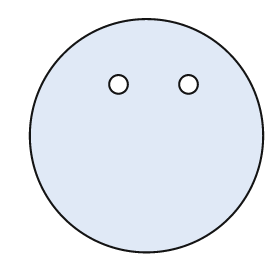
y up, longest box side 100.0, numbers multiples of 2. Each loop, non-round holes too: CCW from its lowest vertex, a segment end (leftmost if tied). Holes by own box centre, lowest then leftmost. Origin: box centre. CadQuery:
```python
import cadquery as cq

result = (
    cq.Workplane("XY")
    .moveTo(0.0, 0.0)
    .circle(50.0)
    .moveTo(-12.0, 22.0)
    .circle(4.0)
    .moveTo(18.0, 22.0)
    .circle(4.0)
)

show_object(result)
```